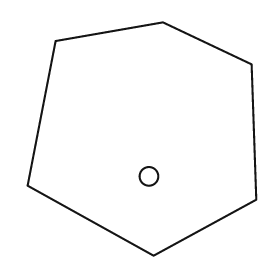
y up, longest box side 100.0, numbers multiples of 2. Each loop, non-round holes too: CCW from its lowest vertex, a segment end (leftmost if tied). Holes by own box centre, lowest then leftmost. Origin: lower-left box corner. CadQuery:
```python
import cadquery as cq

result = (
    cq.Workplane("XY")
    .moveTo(54.0, 0.0)
    .lineTo(98.0, 24.0)
    .lineTo(96.0, 82.0)
    .lineTo(58.0, 100.0)
    .lineTo(12.0, 92.0)
    .lineTo(0.0, 30.0)
    .close()
    .moveTo(52.0, 34.0)
    .circle(4.0)
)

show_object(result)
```